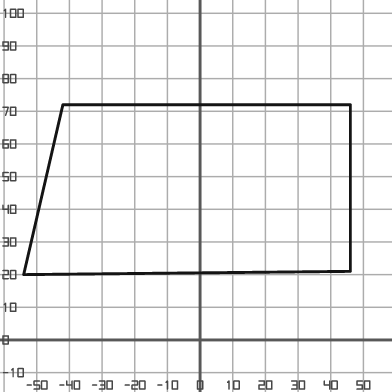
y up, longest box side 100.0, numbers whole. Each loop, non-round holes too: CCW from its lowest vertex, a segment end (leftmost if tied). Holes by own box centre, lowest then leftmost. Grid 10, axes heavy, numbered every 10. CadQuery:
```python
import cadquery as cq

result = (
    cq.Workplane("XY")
    .moveTo(-54.0, 20.0)
    .lineTo(46.0, 21.0)
    .lineTo(46.0, 72.0)
    .lineTo(-42.0, 72.0)
    .close()
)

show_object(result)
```